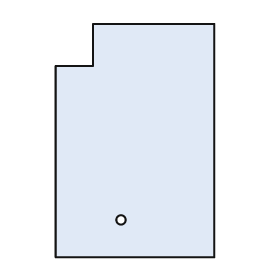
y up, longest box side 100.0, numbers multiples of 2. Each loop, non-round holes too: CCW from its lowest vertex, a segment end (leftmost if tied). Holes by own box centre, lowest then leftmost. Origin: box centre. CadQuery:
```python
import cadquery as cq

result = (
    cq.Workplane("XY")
    .moveTo(-34.0, -50.0)
    .lineTo(34.0, -50.0)
    .lineTo(34.0, 50.0)
    .lineTo(-18.0, 50.0)
    .lineTo(-18.0, 32.0)
    .lineTo(-34.0, 32.0)
    .close()
    .moveTo(-6.0, -34.0)
    .circle(2.0)
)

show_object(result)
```